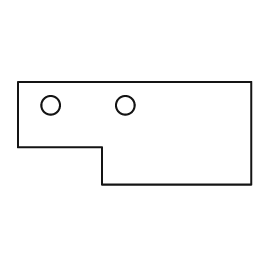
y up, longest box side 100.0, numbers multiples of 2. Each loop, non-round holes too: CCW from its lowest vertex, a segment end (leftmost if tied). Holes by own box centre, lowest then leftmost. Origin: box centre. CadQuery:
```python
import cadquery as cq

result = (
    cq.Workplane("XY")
    .moveTo(-14.0, -22.0)
    .lineTo(50.0, -22.0)
    .lineTo(50.0, 22.0)
    .lineTo(-50.0, 22.0)
    .lineTo(-50.0, -6.0)
    .lineTo(-14.0, -6.0)
    .close()
    .moveTo(-36.0, 12.0)
    .circle(4.0)
    .moveTo(-4.0, 12.0)
    .circle(4.0)
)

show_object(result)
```